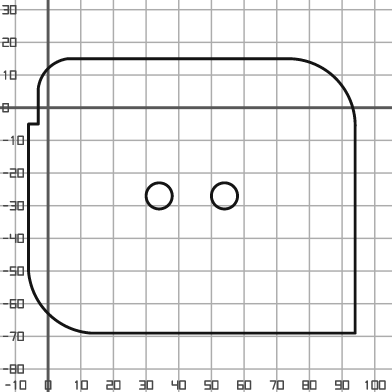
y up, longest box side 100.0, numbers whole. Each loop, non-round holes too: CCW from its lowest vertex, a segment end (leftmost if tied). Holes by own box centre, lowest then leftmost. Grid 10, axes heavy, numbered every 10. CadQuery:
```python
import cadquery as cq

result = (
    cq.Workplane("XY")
    .moveTo(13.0, -69.0)
    .lineTo(94.0, -69.0)
    .lineTo(94.0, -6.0)
    .threePointArc((88.0, 9.0), (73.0, 15.0))
    .lineTo(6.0, 15.0)
    .threePointArc((0.0, 12.0), (-3.0, 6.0))
    .lineTo(-3.0, -5.0)
    .lineTo(-6.0, -5.0)
    .lineTo(-6.0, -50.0)
    .threePointArc((0.0, -63.0), (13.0, -69.0))
    .close()
    .moveTo(34.0, -27.0)
    .circle(4.0)
    .moveTo(54.0, -27.0)
    .circle(4.0)
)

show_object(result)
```